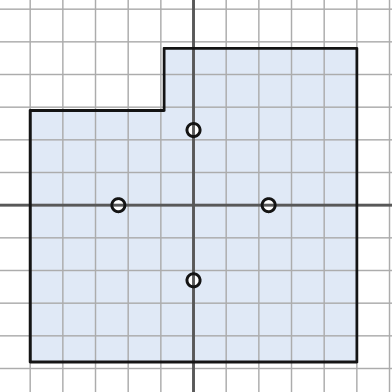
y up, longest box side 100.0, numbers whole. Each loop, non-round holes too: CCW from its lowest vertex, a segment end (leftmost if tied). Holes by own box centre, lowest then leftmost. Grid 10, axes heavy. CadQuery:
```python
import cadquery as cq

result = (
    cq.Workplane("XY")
    .moveTo(-50.0, -48.0)
    .lineTo(50.0, -48.0)
    .lineTo(50.0, 48.0)
    .lineTo(-9.0, 48.0)
    .lineTo(-9.0, 29.0)
    .lineTo(-50.0, 29.0)
    .close()
    .moveTo(0.0, -23.0)
    .circle(2.0)
    .moveTo(-23.0, 0.0)
    .circle(2.0)
    .moveTo(23.0, 0.0)
    .circle(2.0)
    .moveTo(0.0, 23.0)
    .circle(2.0)
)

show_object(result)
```